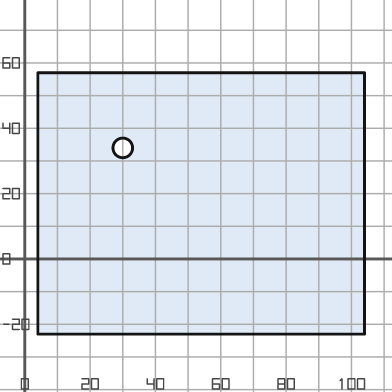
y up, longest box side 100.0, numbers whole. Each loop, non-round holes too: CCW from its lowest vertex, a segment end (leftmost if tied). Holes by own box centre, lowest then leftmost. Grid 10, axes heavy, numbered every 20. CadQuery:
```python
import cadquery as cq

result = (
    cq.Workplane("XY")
    .moveTo(4.0, -23.0)
    .lineTo(104.0, -23.0)
    .lineTo(104.0, 57.0)
    .lineTo(4.0, 57.0)
    .close()
    .moveTo(30.0, 34.0)
    .circle(3.0)
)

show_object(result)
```